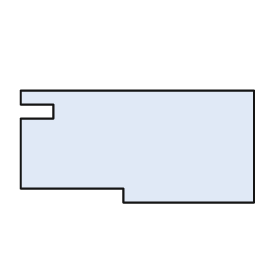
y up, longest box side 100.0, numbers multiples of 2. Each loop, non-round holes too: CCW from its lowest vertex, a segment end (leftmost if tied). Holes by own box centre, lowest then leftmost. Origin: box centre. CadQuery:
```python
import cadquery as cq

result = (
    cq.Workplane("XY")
    .moveTo(-6.0, -24.0)
    .lineTo(50.0, -24.0)
    .lineTo(50.0, 24.0)
    .lineTo(-50.0, 24.0)
    .lineTo(-50.0, 18.0)
    .lineTo(-36.0, 18.0)
    .lineTo(-36.0, 12.0)
    .lineTo(-50.0, 12.0)
    .lineTo(-50.0, -18.0)
    .lineTo(-6.0, -18.0)
    .close()
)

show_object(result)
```